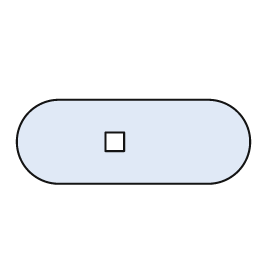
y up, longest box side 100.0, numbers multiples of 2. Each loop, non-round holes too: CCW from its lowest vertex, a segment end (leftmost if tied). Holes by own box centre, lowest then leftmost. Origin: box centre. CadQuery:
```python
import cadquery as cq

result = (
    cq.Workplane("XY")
    .moveTo(-32.0, -18.0)
    .lineTo(32.0, -18.0)
    .threePointArc((50.0, 0.0), (32.0, 18.0))
    .lineTo(-32.0, 18.0)
    .threePointArc((-50.0, 0.0), (-32.0, -18.0))
    .close()
    .moveTo(-12.0, -4.0)
    .lineTo(-4.0, -4.0)
    .lineTo(-4.0, 4.0)
    .lineTo(-12.0, 4.0)
    .close()
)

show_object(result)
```